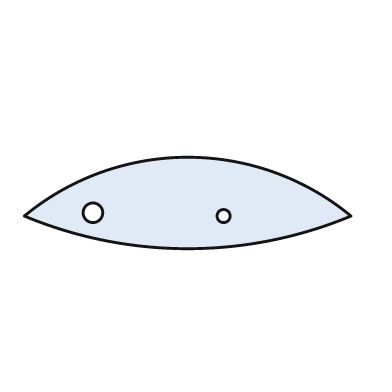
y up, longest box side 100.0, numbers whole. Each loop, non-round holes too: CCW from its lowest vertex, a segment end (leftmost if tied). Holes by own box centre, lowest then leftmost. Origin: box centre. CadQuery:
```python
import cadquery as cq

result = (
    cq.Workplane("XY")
    .moveTo(-50.0, -4.0)
    .threePointArc((0.0, -14.0), (50.0, -4.0))
    .threePointArc((0.0, 14.0), (-50.0, -4.0))
    .close()
    .moveTo(11.0, -4.0)
    .circle(2.0)
    .moveTo(-29.0, -3.0)
    .circle(3.0)
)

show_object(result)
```